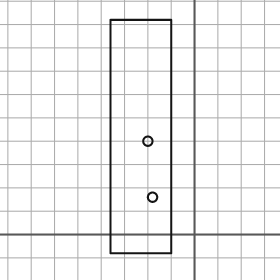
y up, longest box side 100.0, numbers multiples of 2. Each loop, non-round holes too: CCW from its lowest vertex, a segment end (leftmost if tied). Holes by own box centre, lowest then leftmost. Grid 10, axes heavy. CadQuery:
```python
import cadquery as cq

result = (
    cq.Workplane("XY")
    .moveTo(-36.0, -8.0)
    .lineTo(-10.0, -8.0)
    .lineTo(-10.0, 92.0)
    .lineTo(-36.0, 92.0)
    .close()
    .moveTo(-18.0, 16.0)
    .circle(2.0)
    .moveTo(-20.0, 40.0)
    .circle(2.0)
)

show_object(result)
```